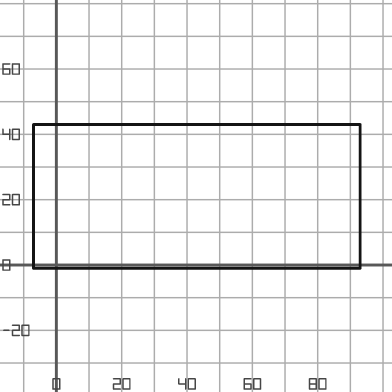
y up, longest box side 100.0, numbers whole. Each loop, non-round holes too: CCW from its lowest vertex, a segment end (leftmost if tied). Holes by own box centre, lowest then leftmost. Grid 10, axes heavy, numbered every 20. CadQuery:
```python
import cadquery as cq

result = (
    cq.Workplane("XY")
    .moveTo(-7.0, -1.0)
    .lineTo(93.0, -1.0)
    .lineTo(93.0, 43.0)
    .lineTo(-7.0, 43.0)
    .close()
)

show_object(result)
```